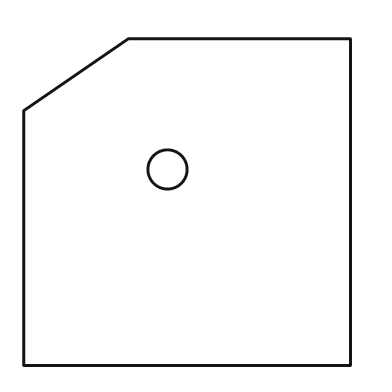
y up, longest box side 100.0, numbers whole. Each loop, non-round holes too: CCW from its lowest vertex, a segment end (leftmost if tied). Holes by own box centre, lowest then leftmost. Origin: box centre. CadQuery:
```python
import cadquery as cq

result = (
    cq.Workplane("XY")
    .moveTo(-50.0, -50.0)
    .lineTo(50.0, -50.0)
    .lineTo(50.0, 50.0)
    .lineTo(-18.0, 50.0)
    .lineTo(-50.0, 28.0)
    .close()
    .moveTo(-6.0, 10.0)
    .circle(6.0)
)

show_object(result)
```